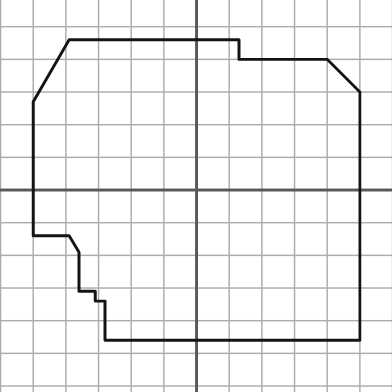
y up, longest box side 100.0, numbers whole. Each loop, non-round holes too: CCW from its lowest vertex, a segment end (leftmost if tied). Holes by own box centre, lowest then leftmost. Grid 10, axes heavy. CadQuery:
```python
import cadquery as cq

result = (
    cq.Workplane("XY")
    .moveTo(-28.0, -46.0)
    .lineTo(50.0, -46.0)
    .lineTo(50.0, 30.0)
    .lineTo(40.0, 40.0)
    .lineTo(13.0, 40.0)
    .lineTo(13.0, 46.0)
    .lineTo(-39.0, 46.0)
    .lineTo(-50.0, 27.0)
    .lineTo(-50.0, -14.0)
    .lineTo(-39.0, -14.0)
    .lineTo(-36.0, -19.0)
    .lineTo(-36.0, -31.0)
    .lineTo(-31.0, -31.0)
    .lineTo(-31.0, -34.0)
    .lineTo(-28.0, -34.0)
    .close()
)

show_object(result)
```